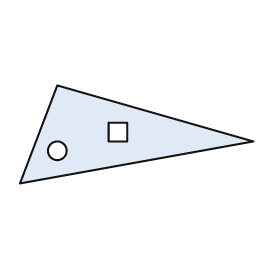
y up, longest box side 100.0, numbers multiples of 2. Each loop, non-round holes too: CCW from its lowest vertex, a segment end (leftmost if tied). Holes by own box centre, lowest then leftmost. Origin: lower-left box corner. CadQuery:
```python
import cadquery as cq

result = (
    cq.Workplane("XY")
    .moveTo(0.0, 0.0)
    .lineTo(100.0, 18.0)
    .lineTo(16.0, 42.0)
    .close()
    .moveTo(16.0, 14.0)
    .circle(4.0)
    .moveTo(38.0, 18.0)
    .lineTo(46.0, 18.0)
    .lineTo(46.0, 26.0)
    .lineTo(38.0, 26.0)
    .close()
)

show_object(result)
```